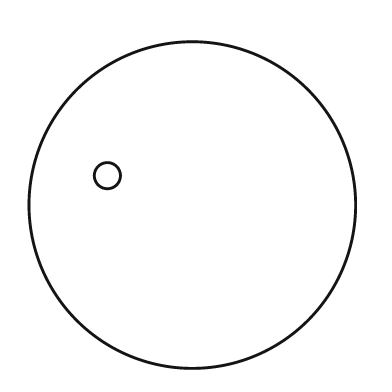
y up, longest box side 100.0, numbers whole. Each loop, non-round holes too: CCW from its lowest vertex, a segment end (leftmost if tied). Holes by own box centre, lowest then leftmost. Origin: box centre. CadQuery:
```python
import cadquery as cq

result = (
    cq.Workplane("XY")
    .moveTo(0.0, 0.0)
    .circle(50.0)
    .moveTo(-26.0, 9.0)
    .circle(4.0)
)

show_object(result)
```